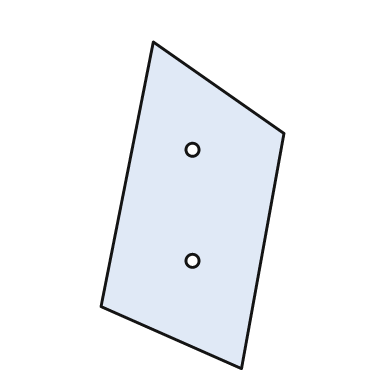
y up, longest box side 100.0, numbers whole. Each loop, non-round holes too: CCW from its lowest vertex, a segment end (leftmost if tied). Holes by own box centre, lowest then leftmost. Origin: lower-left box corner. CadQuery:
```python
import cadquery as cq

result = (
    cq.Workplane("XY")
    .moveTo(43.0, 0.0)
    .lineTo(56.0, 72.0)
    .lineTo(16.0, 100.0)
    .lineTo(0.0, 19.0)
    .close()
    .moveTo(28.0, 33.0)
    .circle(2.0)
    .moveTo(28.0, 67.0)
    .circle(2.0)
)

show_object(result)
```